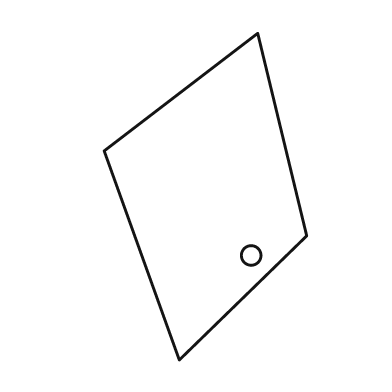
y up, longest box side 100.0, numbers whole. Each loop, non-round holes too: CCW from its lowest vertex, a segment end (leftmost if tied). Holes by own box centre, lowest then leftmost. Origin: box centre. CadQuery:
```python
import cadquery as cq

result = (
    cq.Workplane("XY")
    .moveTo(-8.0, -50.0)
    .lineTo(31.0, -12.0)
    .lineTo(16.0, 50.0)
    .lineTo(-31.0, 14.0)
    .close()
    .moveTo(14.0, -18.0)
    .circle(3.0)
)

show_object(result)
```